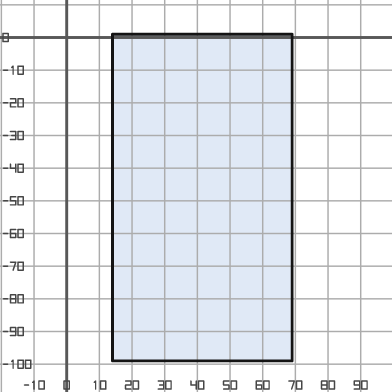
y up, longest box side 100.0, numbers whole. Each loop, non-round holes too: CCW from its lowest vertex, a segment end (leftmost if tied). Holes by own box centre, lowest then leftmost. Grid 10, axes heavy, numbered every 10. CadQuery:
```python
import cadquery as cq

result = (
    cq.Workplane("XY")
    .moveTo(14.0, -99.0)
    .lineTo(69.0, -99.0)
    .lineTo(69.0, 1.0)
    .lineTo(14.0, 1.0)
    .close()
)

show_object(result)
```